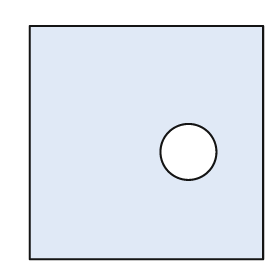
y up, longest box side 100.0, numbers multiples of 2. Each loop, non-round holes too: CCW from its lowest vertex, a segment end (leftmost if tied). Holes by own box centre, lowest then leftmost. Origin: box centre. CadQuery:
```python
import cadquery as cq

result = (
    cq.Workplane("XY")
    .moveTo(-50.0, -50.0)
    .lineTo(50.0, -50.0)
    .lineTo(50.0, 50.0)
    .lineTo(-50.0, 50.0)
    .close()
    .moveTo(18.0, -4.0)
    .circle(12.0)
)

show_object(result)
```